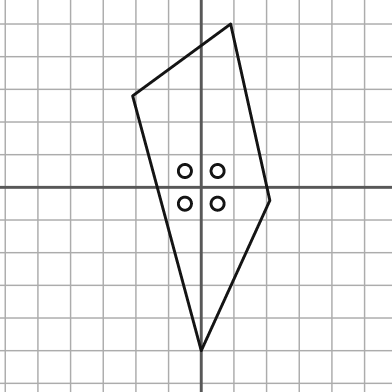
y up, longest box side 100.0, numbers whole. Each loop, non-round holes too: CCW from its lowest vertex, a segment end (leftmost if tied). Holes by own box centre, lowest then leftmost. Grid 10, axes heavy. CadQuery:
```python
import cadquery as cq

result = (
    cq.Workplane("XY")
    .moveTo(0.0, -50.0)
    .lineTo(21.0, -4.0)
    .lineTo(9.0, 50.0)
    .lineTo(-21.0, 28.0)
    .close()
    .moveTo(-5.0, -5.0)
    .circle(2.0)
    .moveTo(5.0, -5.0)
    .circle(2.0)
    .moveTo(-5.0, 5.0)
    .circle(2.0)
    .moveTo(5.0, 5.0)
    .circle(2.0)
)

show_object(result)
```